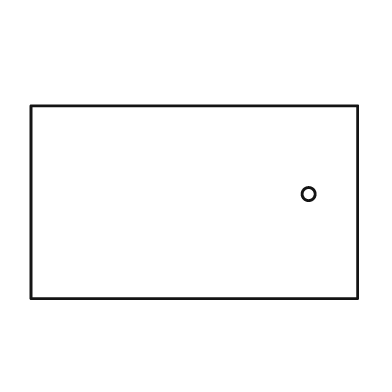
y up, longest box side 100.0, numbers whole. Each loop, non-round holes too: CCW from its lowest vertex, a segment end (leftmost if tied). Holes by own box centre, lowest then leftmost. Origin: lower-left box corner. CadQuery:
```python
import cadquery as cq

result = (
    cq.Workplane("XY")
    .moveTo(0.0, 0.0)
    .lineTo(100.0, 0.0)
    .lineTo(100.0, 59.0)
    .lineTo(0.0, 59.0)
    .close()
    .moveTo(85.0, 32.0)
    .circle(2.0)
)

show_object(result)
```